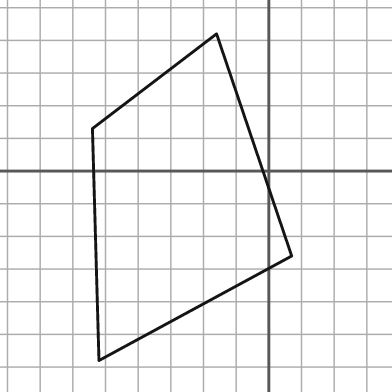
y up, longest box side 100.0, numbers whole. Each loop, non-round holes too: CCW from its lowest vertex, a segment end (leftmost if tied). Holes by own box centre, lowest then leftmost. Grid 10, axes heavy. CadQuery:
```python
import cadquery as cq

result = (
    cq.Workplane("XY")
    .moveTo(-52.0, -58.0)
    .lineTo(7.0, -26.0)
    .lineTo(-16.0, 42.0)
    .lineTo(-54.0, 13.0)
    .close()
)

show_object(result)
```